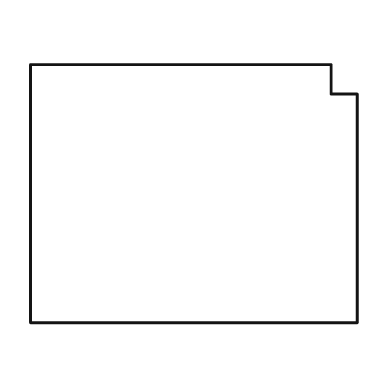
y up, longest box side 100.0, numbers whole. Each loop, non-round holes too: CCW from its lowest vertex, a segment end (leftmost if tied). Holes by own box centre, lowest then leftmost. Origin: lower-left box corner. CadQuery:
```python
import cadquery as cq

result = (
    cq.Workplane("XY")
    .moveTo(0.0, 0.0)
    .lineTo(100.0, 0.0)
    .lineTo(100.0, 70.0)
    .lineTo(92.0, 70.0)
    .lineTo(92.0, 79.0)
    .lineTo(0.0, 79.0)
    .close()
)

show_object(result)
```